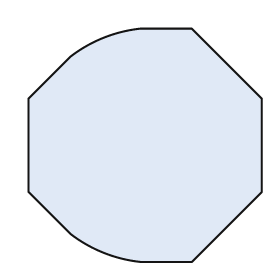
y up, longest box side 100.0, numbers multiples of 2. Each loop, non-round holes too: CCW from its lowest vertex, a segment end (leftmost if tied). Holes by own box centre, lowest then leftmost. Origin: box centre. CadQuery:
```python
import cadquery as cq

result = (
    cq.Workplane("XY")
    .moveTo(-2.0, -50.0)
    .lineTo(20.0, -50.0)
    .lineTo(50.0, -20.0)
    .lineTo(50.0, 20.0)
    .lineTo(20.0, 50.0)
    .lineTo(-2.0, 50.0)
    .threePointArc((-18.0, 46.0), (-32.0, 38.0))
    .lineTo(-50.0, 20.0)
    .lineTo(-50.0, -20.0)
    .lineTo(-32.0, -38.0)
    .threePointArc((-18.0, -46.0), (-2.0, -50.0))
    .close()
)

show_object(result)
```